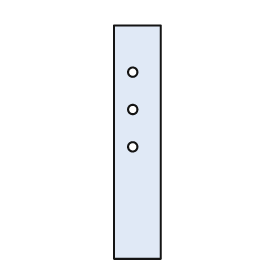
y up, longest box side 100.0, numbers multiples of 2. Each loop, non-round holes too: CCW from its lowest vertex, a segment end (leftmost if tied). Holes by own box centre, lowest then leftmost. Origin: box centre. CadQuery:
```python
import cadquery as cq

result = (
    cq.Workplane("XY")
    .moveTo(-10.0, -50.0)
    .lineTo(10.0, -50.0)
    .lineTo(10.0, 50.0)
    .lineTo(-10.0, 50.0)
    .close()
    .moveTo(-2.0, -2.0)
    .circle(2.0)
    .moveTo(-2.0, 14.0)
    .circle(2.0)
    .moveTo(-2.0, 30.0)
    .circle(2.0)
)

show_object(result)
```